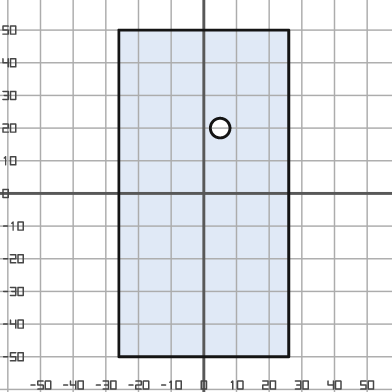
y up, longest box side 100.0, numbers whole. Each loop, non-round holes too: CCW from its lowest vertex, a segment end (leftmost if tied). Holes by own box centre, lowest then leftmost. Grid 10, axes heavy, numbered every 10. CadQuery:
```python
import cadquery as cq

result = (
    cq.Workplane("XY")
    .moveTo(-26.0, -50.0)
    .lineTo(26.0, -50.0)
    .lineTo(26.0, 50.0)
    .lineTo(-26.0, 50.0)
    .close()
    .moveTo(5.0, 20.0)
    .circle(3.0)
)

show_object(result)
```